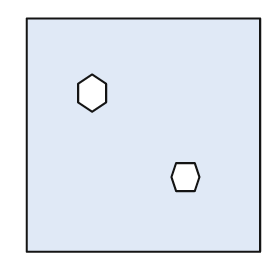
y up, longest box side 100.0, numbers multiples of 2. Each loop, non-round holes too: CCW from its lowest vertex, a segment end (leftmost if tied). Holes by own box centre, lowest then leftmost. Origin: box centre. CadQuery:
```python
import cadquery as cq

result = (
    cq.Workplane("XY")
    .moveTo(-50.0, -50.0)
    .lineTo(50.0, -50.0)
    .lineTo(50.0, 50.0)
    .lineTo(-50.0, 50.0)
    .close()
    .moveTo(14.0, -24.0)
    .lineTo(22.0, -24.0)
    .lineTo(24.0, -18.0)
    .lineTo(22.0, -12.0)
    .lineTo(14.0, -12.0)
    .lineTo(12.0, -18.0)
    .close()
    .moveTo(-22.0, 10.0)
    .lineTo(-16.0, 14.0)
    .lineTo(-16.0, 22.0)
    .lineTo(-22.0, 26.0)
    .lineTo(-28.0, 22.0)
    .lineTo(-28.0, 14.0)
    .close()
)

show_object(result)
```